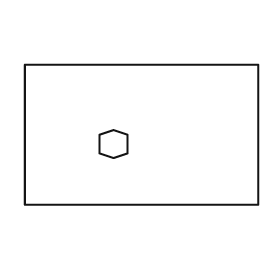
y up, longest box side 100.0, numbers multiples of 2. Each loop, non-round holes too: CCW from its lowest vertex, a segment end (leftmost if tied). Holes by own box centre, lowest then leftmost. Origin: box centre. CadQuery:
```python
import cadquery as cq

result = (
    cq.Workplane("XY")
    .moveTo(-50.0, -30.0)
    .lineTo(50.0, -30.0)
    .lineTo(50.0, 30.0)
    .lineTo(-50.0, 30.0)
    .close()
    .moveTo(-12.0, -10.0)
    .lineTo(-6.0, -8.0)
    .lineTo(-6.0, 0.0)
    .lineTo(-12.0, 2.0)
    .lineTo(-18.0, 0.0)
    .lineTo(-18.0, -8.0)
    .close()
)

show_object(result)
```